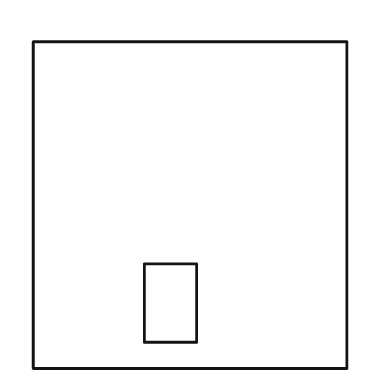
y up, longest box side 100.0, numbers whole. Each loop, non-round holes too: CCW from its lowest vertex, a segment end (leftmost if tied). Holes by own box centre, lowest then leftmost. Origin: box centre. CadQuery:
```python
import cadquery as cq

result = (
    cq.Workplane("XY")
    .moveTo(-48.0, -50.0)
    .lineTo(48.0, -50.0)
    .lineTo(48.0, 50.0)
    .lineTo(-48.0, 50.0)
    .close()
    .moveTo(-14.0, -42.0)
    .lineTo(2.0, -42.0)
    .lineTo(2.0, -18.0)
    .lineTo(-14.0, -18.0)
    .close()
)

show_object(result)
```